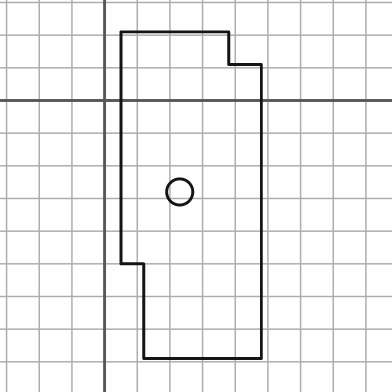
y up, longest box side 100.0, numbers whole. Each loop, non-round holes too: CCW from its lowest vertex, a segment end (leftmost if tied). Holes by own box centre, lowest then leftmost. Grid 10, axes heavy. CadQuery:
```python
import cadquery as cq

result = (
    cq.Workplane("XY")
    .moveTo(12.0, -79.0)
    .lineTo(48.0, -79.0)
    .lineTo(48.0, 11.0)
    .lineTo(38.0, 11.0)
    .lineTo(38.0, 21.0)
    .lineTo(5.0, 21.0)
    .lineTo(5.0, -50.0)
    .lineTo(12.0, -50.0)
    .close()
    .moveTo(23.0, -28.0)
    .circle(4.0)
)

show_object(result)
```